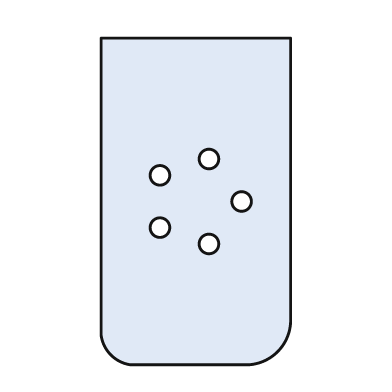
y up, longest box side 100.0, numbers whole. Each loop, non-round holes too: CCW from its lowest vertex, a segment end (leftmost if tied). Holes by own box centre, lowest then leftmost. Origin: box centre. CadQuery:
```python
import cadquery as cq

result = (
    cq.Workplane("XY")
    .moveTo(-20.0, -50.0)
    .lineTo(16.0, -50.0)
    .threePointArc((25.0, -46.0), (29.0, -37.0))
    .lineTo(29.0, 50.0)
    .lineTo(-29.0, 50.0)
    .lineTo(-29.0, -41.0)
    .threePointArc((-26.0, -47.0), (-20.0, -50.0))
    .close()
    .moveTo(4.0, -13.0)
    .circle(3.0)
    .moveTo(-11.0, -8.0)
    .circle(3.0)
    .moveTo(14.0, 0.0)
    .circle(3.0)
    .moveTo(-11.0, 8.0)
    .circle(3.0)
    .moveTo(4.0, 13.0)
    .circle(3.0)
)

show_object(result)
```